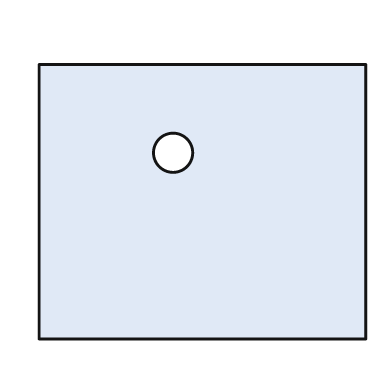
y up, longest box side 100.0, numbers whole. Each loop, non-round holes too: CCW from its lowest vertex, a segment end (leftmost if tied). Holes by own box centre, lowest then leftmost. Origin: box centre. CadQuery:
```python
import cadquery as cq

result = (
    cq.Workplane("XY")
    .moveTo(-50.0, -42.0)
    .lineTo(50.0, -42.0)
    .lineTo(50.0, 42.0)
    .lineTo(-50.0, 42.0)
    .close()
    .moveTo(-9.0, 15.0)
    .circle(6.0)
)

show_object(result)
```